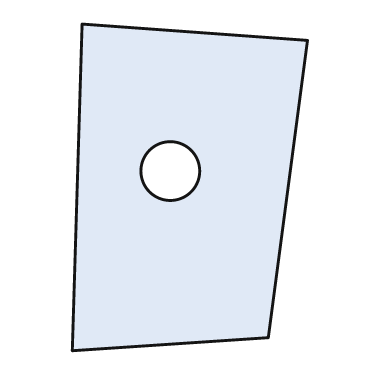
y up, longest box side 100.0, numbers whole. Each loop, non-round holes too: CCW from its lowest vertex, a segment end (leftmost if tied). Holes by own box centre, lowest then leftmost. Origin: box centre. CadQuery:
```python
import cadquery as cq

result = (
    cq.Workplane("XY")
    .moveTo(-36.0, -50.0)
    .lineTo(24.0, -46.0)
    .lineTo(36.0, 45.0)
    .lineTo(-33.0, 50.0)
    .close()
    .moveTo(-6.0, 5.0)
    .circle(9.0)
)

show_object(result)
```